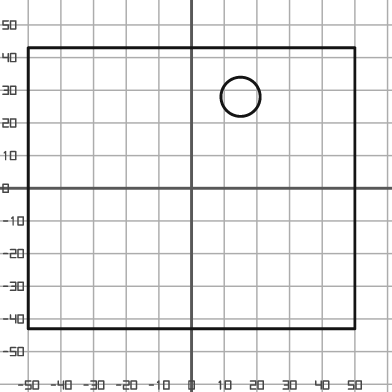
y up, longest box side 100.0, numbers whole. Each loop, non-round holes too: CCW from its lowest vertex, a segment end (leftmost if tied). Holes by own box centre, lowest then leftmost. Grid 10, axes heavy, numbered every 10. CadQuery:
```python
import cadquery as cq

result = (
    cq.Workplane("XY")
    .moveTo(-50.0, -43.0)
    .lineTo(50.0, -43.0)
    .lineTo(50.0, 43.0)
    .lineTo(-50.0, 43.0)
    .close()
    .moveTo(15.0, 28.0)
    .circle(6.0)
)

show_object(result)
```